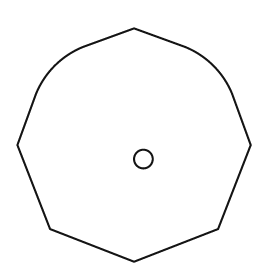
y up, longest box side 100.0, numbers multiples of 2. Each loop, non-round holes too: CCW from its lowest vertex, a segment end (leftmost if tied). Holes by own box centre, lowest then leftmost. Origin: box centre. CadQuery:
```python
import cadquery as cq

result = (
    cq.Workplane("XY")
    .moveTo(0.0, -50.0)
    .lineTo(36.0, -36.0)
    .lineTo(50.0, 0.0)
    .lineTo(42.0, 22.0)
    .threePointArc((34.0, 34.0), (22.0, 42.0))
    .lineTo(0.0, 50.0)
    .lineTo(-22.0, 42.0)
    .threePointArc((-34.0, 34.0), (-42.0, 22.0))
    .lineTo(-50.0, 0.0)
    .lineTo(-36.0, -36.0)
    .close()
    .moveTo(4.0, -6.0)
    .circle(4.0)
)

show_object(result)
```